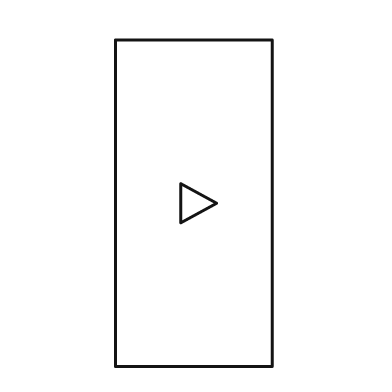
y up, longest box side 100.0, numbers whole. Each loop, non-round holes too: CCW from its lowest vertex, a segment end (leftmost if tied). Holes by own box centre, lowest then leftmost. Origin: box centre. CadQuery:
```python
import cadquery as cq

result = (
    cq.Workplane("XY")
    .moveTo(-24.0, -50.0)
    .lineTo(24.0, -50.0)
    .lineTo(24.0, 50.0)
    .lineTo(-24.0, 50.0)
    .close()
    .moveTo(-4.0, -6.0)
    .lineTo(7.0, 0.0)
    .lineTo(-4.0, 6.0)
    .close()
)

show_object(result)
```